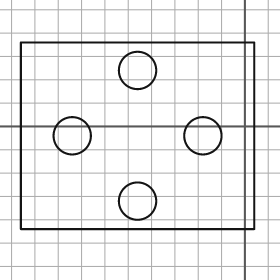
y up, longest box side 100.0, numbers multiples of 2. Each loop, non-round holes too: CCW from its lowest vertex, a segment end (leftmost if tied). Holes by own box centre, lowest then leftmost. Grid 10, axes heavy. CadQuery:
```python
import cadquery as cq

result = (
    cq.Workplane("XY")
    .moveTo(-96.0, -44.0)
    .lineTo(4.0, -44.0)
    .lineTo(4.0, 36.0)
    .lineTo(-96.0, 36.0)
    .close()
    .moveTo(-46.0, -32.0)
    .circle(8.0)
    .moveTo(-74.0, -4.0)
    .circle(8.0)
    .moveTo(-18.0, -4.0)
    .circle(8.0)
    .moveTo(-46.0, 24.0)
    .circle(8.0)
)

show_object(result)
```